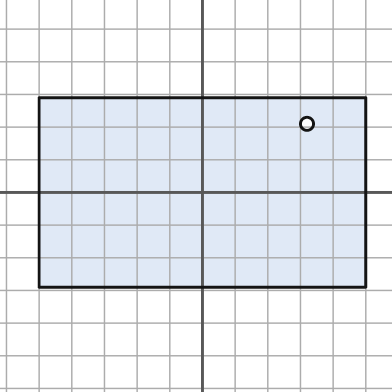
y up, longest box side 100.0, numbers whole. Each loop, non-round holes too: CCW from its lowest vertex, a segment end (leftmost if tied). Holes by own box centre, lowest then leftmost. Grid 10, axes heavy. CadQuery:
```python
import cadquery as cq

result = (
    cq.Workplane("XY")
    .moveTo(-50.0, -29.0)
    .lineTo(50.0, -29.0)
    .lineTo(50.0, 29.0)
    .lineTo(-50.0, 29.0)
    .close()
    .moveTo(32.0, 21.0)
    .circle(2.0)
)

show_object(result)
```